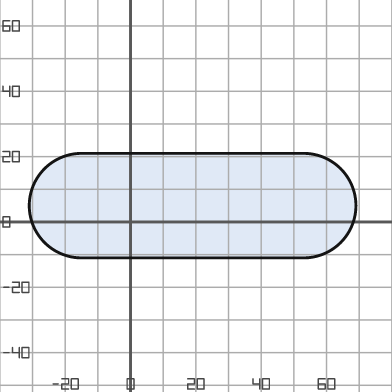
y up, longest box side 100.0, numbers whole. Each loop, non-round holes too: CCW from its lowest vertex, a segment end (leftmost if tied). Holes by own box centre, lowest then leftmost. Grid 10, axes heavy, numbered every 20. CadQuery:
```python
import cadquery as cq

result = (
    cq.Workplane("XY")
    .moveTo(-15.0, -11.0)
    .lineTo(53.0, -11.0)
    .threePointArc((69.0, 5.0), (53.0, 21.0))
    .lineTo(-15.0, 21.0)
    .threePointArc((-31.0, 5.0), (-15.0, -11.0))
    .close()
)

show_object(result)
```